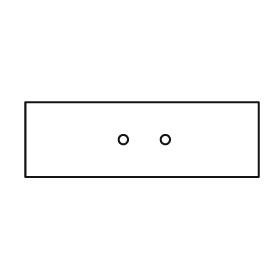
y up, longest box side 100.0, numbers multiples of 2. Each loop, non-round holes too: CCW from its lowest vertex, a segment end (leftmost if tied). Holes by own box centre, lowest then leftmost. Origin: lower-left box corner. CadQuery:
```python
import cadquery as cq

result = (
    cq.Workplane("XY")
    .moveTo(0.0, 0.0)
    .lineTo(100.0, 0.0)
    .lineTo(100.0, 32.0)
    .lineTo(0.0, 32.0)
    .close()
    .moveTo(42.0, 16.0)
    .circle(2.0)
    .moveTo(60.0, 16.0)
    .circle(2.0)
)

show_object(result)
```